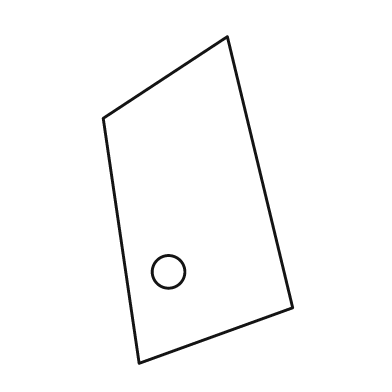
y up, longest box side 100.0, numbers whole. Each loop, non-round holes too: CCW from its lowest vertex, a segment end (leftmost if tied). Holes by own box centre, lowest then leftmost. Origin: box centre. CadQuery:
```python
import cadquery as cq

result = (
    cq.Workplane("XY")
    .moveTo(-18.0, -50.0)
    .lineTo(29.0, -33.0)
    .lineTo(9.0, 50.0)
    .lineTo(-29.0, 25.0)
    .close()
    .moveTo(-9.0, -22.0)
    .circle(5.0)
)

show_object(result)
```